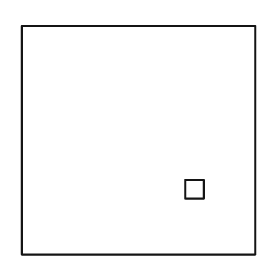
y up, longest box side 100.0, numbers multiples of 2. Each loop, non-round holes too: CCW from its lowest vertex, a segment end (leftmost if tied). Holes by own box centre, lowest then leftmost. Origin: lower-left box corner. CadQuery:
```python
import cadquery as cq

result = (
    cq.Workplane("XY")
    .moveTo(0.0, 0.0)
    .lineTo(100.0, 0.0)
    .lineTo(100.0, 98.0)
    .lineTo(0.0, 98.0)
    .close()
    .moveTo(70.0, 24.0)
    .lineTo(78.0, 24.0)
    .lineTo(78.0, 32.0)
    .lineTo(70.0, 32.0)
    .close()
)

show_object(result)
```